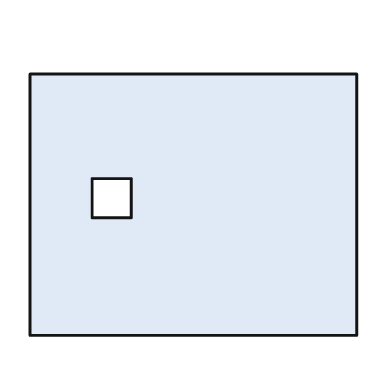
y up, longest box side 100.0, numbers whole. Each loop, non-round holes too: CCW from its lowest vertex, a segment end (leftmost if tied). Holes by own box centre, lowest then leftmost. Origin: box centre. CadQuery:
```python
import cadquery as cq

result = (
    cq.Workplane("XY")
    .moveTo(-50.0, -40.0)
    .lineTo(50.0, -40.0)
    .lineTo(50.0, 40.0)
    .lineTo(-50.0, 40.0)
    .close()
    .moveTo(-31.0, -4.0)
    .lineTo(-19.0, -4.0)
    .lineTo(-19.0, 8.0)
    .lineTo(-31.0, 8.0)
    .close()
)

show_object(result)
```